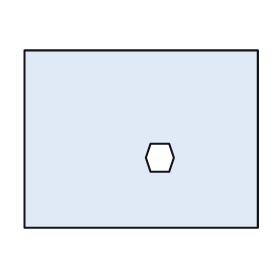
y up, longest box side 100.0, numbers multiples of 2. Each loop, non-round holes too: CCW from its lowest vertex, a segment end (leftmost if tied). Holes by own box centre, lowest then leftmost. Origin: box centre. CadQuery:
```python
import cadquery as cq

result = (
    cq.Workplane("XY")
    .moveTo(-50.0, -38.0)
    .lineTo(50.0, -38.0)
    .lineTo(50.0, 38.0)
    .lineTo(-50.0, 38.0)
    .close()
    .moveTo(4.0, -14.0)
    .lineTo(12.0, -14.0)
    .lineTo(14.0, -8.0)
    .lineTo(12.0, -2.0)
    .lineTo(4.0, -2.0)
    .lineTo(2.0, -8.0)
    .close()
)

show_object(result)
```